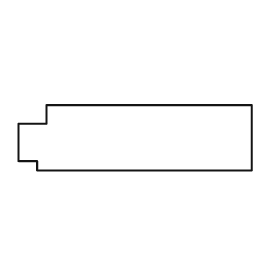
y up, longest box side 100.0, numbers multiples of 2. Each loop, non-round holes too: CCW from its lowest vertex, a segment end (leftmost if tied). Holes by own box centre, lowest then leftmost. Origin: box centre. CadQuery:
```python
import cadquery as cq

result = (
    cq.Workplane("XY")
    .moveTo(-42.0, -14.0)
    .lineTo(50.0, -14.0)
    .lineTo(50.0, 14.0)
    .lineTo(-38.0, 14.0)
    .lineTo(-38.0, 6.0)
    .lineTo(-50.0, 6.0)
    .lineTo(-50.0, -10.0)
    .lineTo(-42.0, -10.0)
    .close()
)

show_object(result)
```